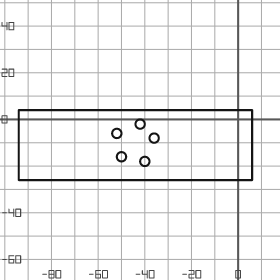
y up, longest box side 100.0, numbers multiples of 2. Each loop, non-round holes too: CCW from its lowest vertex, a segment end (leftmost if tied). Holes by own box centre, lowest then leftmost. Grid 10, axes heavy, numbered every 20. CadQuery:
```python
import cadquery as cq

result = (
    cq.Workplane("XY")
    .moveTo(-94.0, -26.0)
    .lineTo(6.0, -26.0)
    .lineTo(6.0, 4.0)
    .lineTo(-94.0, 4.0)
    .close()
    .moveTo(-40.0, -18.0)
    .circle(2.0)
    .moveTo(-50.0, -16.0)
    .circle(2.0)
    .moveTo(-36.0, -8.0)
    .circle(2.0)
    .moveTo(-52.0, -6.0)
    .circle(2.0)
    .moveTo(-42.0, -2.0)
    .circle(2.0)
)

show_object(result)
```